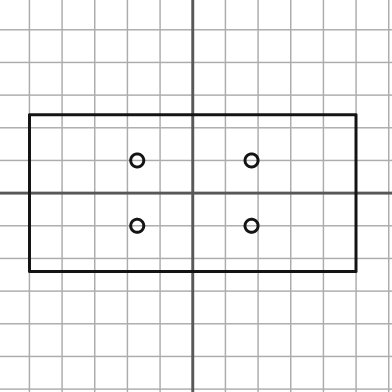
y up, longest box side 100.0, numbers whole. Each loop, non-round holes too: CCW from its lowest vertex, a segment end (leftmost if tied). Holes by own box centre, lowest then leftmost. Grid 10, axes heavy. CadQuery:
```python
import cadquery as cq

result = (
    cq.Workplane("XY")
    .moveTo(-50.0, -24.0)
    .lineTo(50.0, -24.0)
    .lineTo(50.0, 24.0)
    .lineTo(-50.0, 24.0)
    .close()
    .moveTo(-17.0, -10.0)
    .circle(2.0)
    .moveTo(18.0, -10.0)
    .circle(2.0)
    .moveTo(-17.0, 10.0)
    .circle(2.0)
    .moveTo(18.0, 10.0)
    .circle(2.0)
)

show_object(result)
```